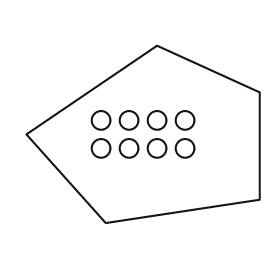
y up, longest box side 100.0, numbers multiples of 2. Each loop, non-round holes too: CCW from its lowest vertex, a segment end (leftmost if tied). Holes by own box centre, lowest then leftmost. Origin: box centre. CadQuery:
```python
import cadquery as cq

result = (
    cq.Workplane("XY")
    .moveTo(-16.0, -38.0)
    .lineTo(50.0, -28.0)
    .lineTo(50.0, 18.0)
    .lineTo(6.0, 38.0)
    .lineTo(-50.0, 0.0)
    .close()
    .moveTo(-18.0, -6.0)
    .circle(4.0)
    .moveTo(-6.0, -6.0)
    .circle(4.0)
    .moveTo(6.0, -6.0)
    .circle(4.0)
    .moveTo(18.0, -6.0)
    .circle(4.0)
    .moveTo(-18.0, 6.0)
    .circle(4.0)
    .moveTo(-6.0, 6.0)
    .circle(4.0)
    .moveTo(6.0, 6.0)
    .circle(4.0)
    .moveTo(18.0, 6.0)
    .circle(4.0)
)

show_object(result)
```